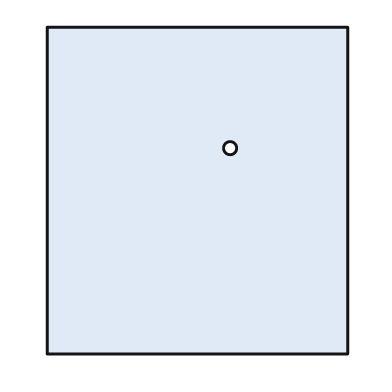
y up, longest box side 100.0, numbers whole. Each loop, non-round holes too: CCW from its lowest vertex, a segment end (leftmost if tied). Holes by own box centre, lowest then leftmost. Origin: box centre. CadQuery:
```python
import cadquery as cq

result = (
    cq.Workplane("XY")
    .moveTo(-46.0, -50.0)
    .lineTo(46.0, -50.0)
    .lineTo(46.0, 50.0)
    .lineTo(-46.0, 50.0)
    .close()
    .moveTo(10.0, 13.0)
    .circle(2.0)
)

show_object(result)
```